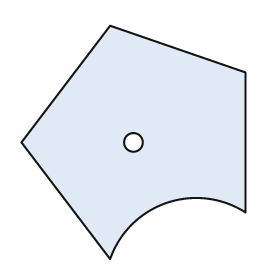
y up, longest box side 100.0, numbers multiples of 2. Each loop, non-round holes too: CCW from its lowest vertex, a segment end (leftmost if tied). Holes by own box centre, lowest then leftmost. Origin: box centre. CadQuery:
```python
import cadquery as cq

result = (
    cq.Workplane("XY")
    .moveTo(-10.0, -50.0)
    .threePointArc((14.0, -26.0), (48.0, -30.0))
    .lineTo(48.0, 30.0)
    .lineTo(-10.0, 50.0)
    .lineTo(-48.0, 0.0)
    .close()
    .moveTo(0.0, 0.0)
    .circle(4.0)
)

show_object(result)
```